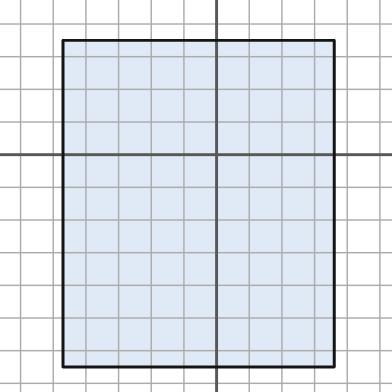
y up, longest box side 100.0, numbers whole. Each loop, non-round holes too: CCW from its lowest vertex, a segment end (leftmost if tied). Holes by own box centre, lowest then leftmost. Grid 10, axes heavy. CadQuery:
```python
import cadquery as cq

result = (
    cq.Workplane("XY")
    .moveTo(-47.0, -65.0)
    .lineTo(36.0, -65.0)
    .lineTo(36.0, 35.0)
    .lineTo(-47.0, 35.0)
    .close()
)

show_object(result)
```